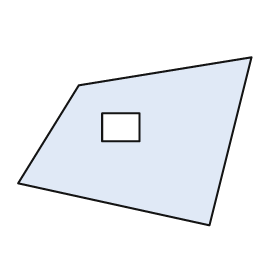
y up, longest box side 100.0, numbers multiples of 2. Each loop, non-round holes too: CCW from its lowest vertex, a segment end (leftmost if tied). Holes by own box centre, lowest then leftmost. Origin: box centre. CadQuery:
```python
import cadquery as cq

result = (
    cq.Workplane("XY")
    .moveTo(32.0, -36.0)
    .lineTo(50.0, 36.0)
    .lineTo(-24.0, 24.0)
    .lineTo(-50.0, -18.0)
    .close()
    .moveTo(-14.0, 0.0)
    .lineTo(2.0, 0.0)
    .lineTo(2.0, 12.0)
    .lineTo(-14.0, 12.0)
    .close()
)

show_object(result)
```